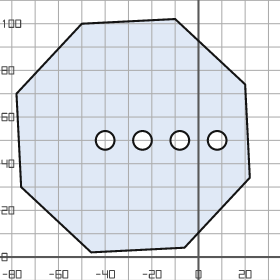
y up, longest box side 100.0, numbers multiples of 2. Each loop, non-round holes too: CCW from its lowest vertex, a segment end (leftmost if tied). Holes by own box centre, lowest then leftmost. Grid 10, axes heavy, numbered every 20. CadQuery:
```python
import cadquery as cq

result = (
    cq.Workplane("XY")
    .moveTo(-46.0, 2.0)
    .lineTo(-6.0, 4.0)
    .lineTo(22.0, 34.0)
    .lineTo(20.0, 74.0)
    .lineTo(-10.0, 102.0)
    .lineTo(-50.0, 100.0)
    .lineTo(-78.0, 70.0)
    .lineTo(-76.0, 30.0)
    .close()
    .moveTo(-40.0, 50.0)
    .circle(4.0)
    .moveTo(-24.0, 50.0)
    .circle(4.0)
    .moveTo(-8.0, 50.0)
    .circle(4.0)
    .moveTo(8.0, 50.0)
    .circle(4.0)
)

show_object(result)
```